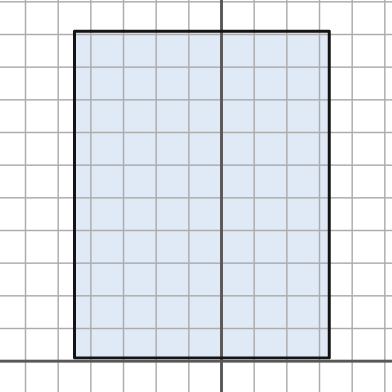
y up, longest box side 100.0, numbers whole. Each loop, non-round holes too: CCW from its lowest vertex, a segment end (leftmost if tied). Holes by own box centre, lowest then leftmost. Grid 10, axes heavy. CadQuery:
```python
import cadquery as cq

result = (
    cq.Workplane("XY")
    .moveTo(-45.0, 1.0)
    .lineTo(33.0, 1.0)
    .lineTo(33.0, 101.0)
    .lineTo(-45.0, 101.0)
    .close()
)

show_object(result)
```